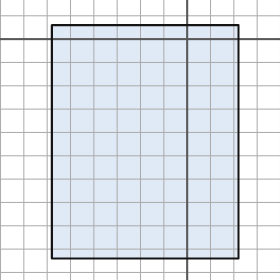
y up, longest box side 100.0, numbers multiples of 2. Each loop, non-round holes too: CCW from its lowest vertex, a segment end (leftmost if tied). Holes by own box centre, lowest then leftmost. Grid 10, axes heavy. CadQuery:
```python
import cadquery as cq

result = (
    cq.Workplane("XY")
    .moveTo(-58.0, -94.0)
    .lineTo(22.0, -94.0)
    .lineTo(22.0, 6.0)
    .lineTo(-58.0, 6.0)
    .close()
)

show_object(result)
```